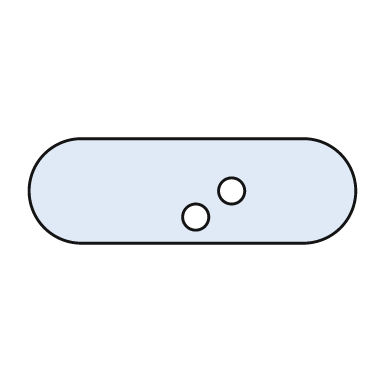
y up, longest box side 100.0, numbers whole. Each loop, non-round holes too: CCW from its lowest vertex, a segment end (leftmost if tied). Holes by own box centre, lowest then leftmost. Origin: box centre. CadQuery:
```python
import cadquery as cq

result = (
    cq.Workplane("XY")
    .moveTo(-34.0, -16.0)
    .lineTo(34.0, -16.0)
    .threePointArc((50.0, 0.0), (34.0, 16.0))
    .lineTo(-34.0, 16.0)
    .threePointArc((-50.0, 0.0), (-34.0, -16.0))
    .close()
    .moveTo(1.0, -8.0)
    .circle(4.0)
    .moveTo(12.0, 0.0)
    .circle(4.0)
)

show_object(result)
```